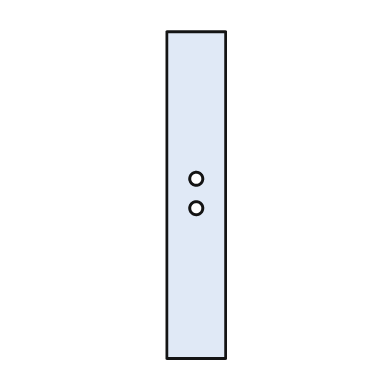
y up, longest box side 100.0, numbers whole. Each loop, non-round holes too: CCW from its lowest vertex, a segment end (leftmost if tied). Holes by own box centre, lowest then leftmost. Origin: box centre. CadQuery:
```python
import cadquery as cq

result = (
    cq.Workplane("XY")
    .moveTo(-9.0, -50.0)
    .lineTo(9.0, -50.0)
    .lineTo(9.0, 50.0)
    .lineTo(-9.0, 50.0)
    .close()
    .moveTo(0.0, -4.0)
    .circle(2.0)
    .moveTo(0.0, 5.0)
    .circle(2.0)
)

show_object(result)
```